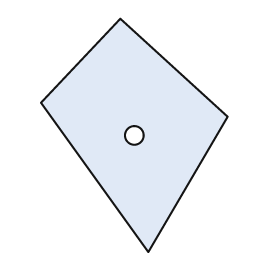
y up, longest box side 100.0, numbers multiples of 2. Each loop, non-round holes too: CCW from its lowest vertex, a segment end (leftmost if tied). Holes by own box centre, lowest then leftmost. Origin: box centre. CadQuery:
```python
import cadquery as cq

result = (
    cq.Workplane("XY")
    .moveTo(6.0, -50.0)
    .lineTo(40.0, 8.0)
    .lineTo(-6.0, 50.0)
    .lineTo(-40.0, 14.0)
    .close()
    .moveTo(0.0, 0.0)
    .circle(4.0)
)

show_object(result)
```